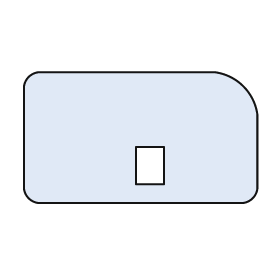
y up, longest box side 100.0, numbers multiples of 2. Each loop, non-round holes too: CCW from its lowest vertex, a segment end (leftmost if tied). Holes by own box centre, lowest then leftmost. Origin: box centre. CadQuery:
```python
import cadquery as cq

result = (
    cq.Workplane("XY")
    .moveTo(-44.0, -28.0)
    .lineTo(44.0, -28.0)
    .threePointArc((48.0, -26.0), (50.0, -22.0))
    .lineTo(50.0, 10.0)
    .threePointArc((44.0, 22.0), (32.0, 28.0))
    .lineTo(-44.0, 28.0)
    .threePointArc((-48.0, 26.0), (-50.0, 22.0))
    .lineTo(-50.0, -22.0)
    .threePointArc((-48.0, -26.0), (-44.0, -28.0))
    .close()
    .moveTo(-2.0, -20.0)
    .lineTo(10.0, -20.0)
    .lineTo(10.0, -4.0)
    .lineTo(-2.0, -4.0)
    .close()
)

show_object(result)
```